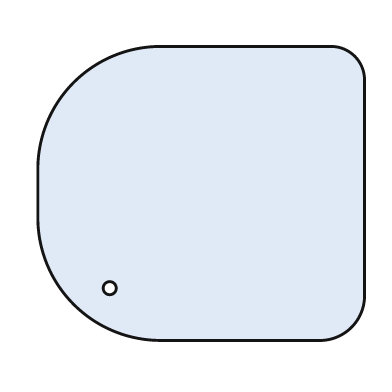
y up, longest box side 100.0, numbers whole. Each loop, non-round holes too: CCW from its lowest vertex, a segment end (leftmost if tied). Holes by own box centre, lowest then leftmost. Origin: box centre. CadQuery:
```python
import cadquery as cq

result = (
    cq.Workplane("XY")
    .moveTo(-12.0, -45.0)
    .lineTo(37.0, -45.0)
    .threePointArc((46.0, -41.0), (50.0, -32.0))
    .lineTo(50.0, 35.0)
    .threePointArc((47.0, 42.0), (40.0, 45.0))
    .lineTo(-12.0, 45.0)
    .threePointArc((-39.0, 34.0), (-50.0, 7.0))
    .lineTo(-50.0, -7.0)
    .threePointArc((-39.0, -34.0), (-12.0, -45.0))
    .close()
    .moveTo(-28.0, -29.0)
    .circle(2.0)
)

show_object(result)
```